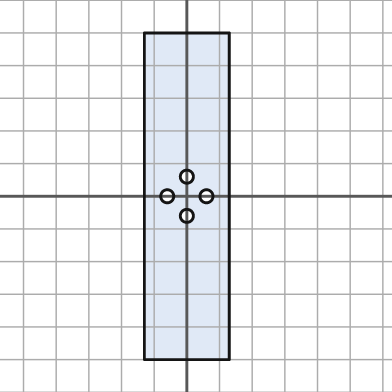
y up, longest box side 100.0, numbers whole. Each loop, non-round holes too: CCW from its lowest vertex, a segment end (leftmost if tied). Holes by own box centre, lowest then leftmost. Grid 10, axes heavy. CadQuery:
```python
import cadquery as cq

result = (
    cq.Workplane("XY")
    .moveTo(-13.0, -50.0)
    .lineTo(13.0, -50.0)
    .lineTo(13.0, 50.0)
    .lineTo(-13.0, 50.0)
    .close()
    .moveTo(0.0, -6.0)
    .circle(2.0)
    .moveTo(-6.0, 0.0)
    .circle(2.0)
    .moveTo(6.0, 0.0)
    .circle(2.0)
    .moveTo(0.0, 6.0)
    .circle(2.0)
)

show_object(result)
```